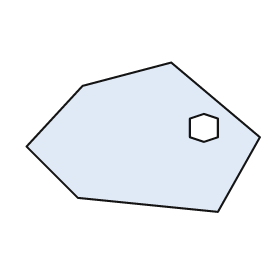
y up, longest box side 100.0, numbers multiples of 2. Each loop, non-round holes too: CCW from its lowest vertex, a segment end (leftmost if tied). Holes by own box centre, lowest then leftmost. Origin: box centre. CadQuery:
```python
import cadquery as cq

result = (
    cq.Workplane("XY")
    .moveTo(32.0, -32.0)
    .lineTo(50.0, 0.0)
    .lineTo(12.0, 32.0)
    .lineTo(-26.0, 22.0)
    .lineTo(-50.0, -4.0)
    .lineTo(-28.0, -26.0)
    .close()
    .moveTo(26.0, -2.0)
    .lineTo(32.0, 0.0)
    .lineTo(32.0, 8.0)
    .lineTo(26.0, 10.0)
    .lineTo(20.0, 8.0)
    .lineTo(20.0, 0.0)
    .close()
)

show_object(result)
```